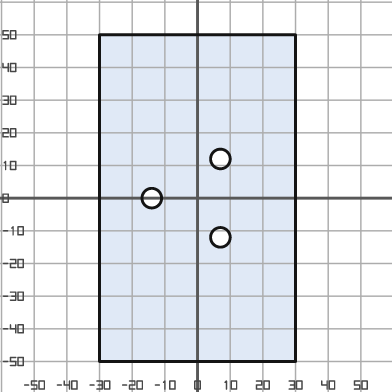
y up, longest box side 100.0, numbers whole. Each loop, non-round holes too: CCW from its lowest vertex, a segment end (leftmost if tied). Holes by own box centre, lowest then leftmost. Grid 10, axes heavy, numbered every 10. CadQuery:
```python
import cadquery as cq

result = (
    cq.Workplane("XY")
    .moveTo(-30.0, -50.0)
    .lineTo(30.0, -50.0)
    .lineTo(30.0, 50.0)
    .lineTo(-30.0, 50.0)
    .close()
    .moveTo(7.0, -12.0)
    .circle(3.0)
    .moveTo(-14.0, 0.0)
    .circle(3.0)
    .moveTo(7.0, 12.0)
    .circle(3.0)
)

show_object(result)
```